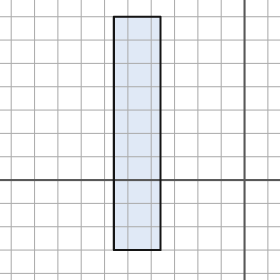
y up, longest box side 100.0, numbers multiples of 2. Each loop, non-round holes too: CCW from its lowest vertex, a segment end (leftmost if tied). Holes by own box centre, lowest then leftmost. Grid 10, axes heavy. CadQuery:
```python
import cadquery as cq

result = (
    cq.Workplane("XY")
    .moveTo(-56.0, -30.0)
    .lineTo(-36.0, -30.0)
    .lineTo(-36.0, 70.0)
    .lineTo(-56.0, 70.0)
    .close()
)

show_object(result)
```